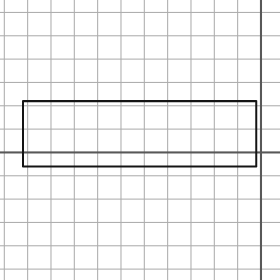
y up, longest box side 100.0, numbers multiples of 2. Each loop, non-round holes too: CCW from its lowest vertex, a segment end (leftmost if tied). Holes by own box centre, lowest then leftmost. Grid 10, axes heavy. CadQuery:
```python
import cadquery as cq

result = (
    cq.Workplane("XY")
    .moveTo(-102.0, -6.0)
    .lineTo(-2.0, -6.0)
    .lineTo(-2.0, 22.0)
    .lineTo(-102.0, 22.0)
    .close()
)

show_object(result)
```